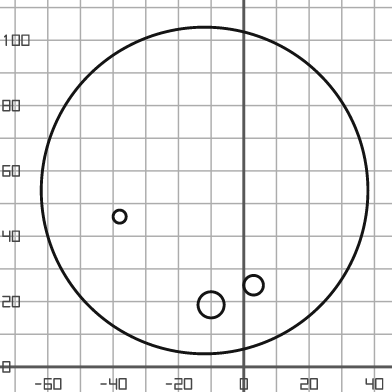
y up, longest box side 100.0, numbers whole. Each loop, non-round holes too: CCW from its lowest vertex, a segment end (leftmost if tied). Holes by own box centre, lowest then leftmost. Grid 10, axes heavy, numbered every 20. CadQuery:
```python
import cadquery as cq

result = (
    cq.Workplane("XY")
    .moveTo(-12.0, 54.0)
    .circle(50.0)
    .moveTo(-10.0, 19.0)
    .circle(4.0)
    .moveTo(3.0, 25.0)
    .circle(3.0)
    .moveTo(-38.0, 46.0)
    .circle(2.0)
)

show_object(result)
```